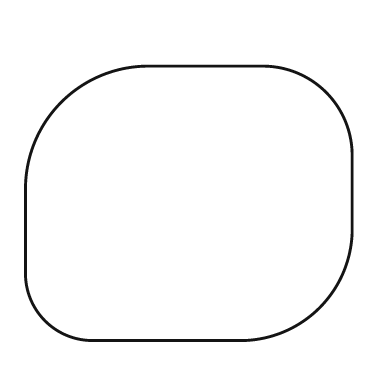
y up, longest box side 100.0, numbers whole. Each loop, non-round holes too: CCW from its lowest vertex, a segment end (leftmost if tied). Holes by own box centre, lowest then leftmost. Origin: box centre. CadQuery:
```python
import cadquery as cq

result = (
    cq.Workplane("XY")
    .moveTo(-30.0, -42.0)
    .lineTo(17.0, -42.0)
    .threePointArc((40.0, -32.0), (50.0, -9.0))
    .lineTo(50.0, 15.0)
    .threePointArc((42.0, 34.0), (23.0, 42.0))
    .lineTo(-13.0, 42.0)
    .threePointArc((-39.0, 31.0), (-50.0, 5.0))
    .lineTo(-50.0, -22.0)
    .threePointArc((-44.0, -36.0), (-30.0, -42.0))
    .close()
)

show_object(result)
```